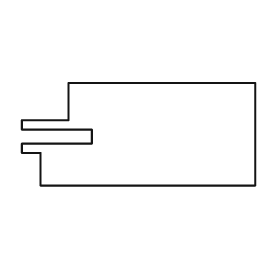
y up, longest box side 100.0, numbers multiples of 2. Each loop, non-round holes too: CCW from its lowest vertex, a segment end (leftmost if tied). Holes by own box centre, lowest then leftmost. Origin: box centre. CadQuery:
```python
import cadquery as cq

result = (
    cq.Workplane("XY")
    .moveTo(-42.0, -22.0)
    .lineTo(50.0, -22.0)
    .lineTo(50.0, 22.0)
    .lineTo(-30.0, 22.0)
    .lineTo(-30.0, 6.0)
    .lineTo(-50.0, 6.0)
    .lineTo(-50.0, 2.0)
    .lineTo(-20.0, 2.0)
    .lineTo(-20.0, -4.0)
    .lineTo(-50.0, -4.0)
    .lineTo(-50.0, -8.0)
    .lineTo(-42.0, -8.0)
    .close()
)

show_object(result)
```